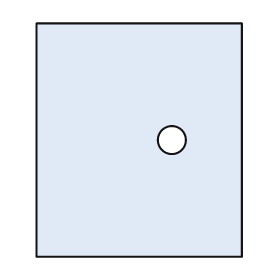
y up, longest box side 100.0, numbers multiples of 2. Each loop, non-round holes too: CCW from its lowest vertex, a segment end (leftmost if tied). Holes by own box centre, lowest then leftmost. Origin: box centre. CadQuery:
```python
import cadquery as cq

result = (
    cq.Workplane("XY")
    .moveTo(-44.0, -50.0)
    .lineTo(44.0, -50.0)
    .lineTo(44.0, 50.0)
    .lineTo(-44.0, 50.0)
    .close()
    .moveTo(14.0, 0.0)
    .circle(6.0)
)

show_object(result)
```